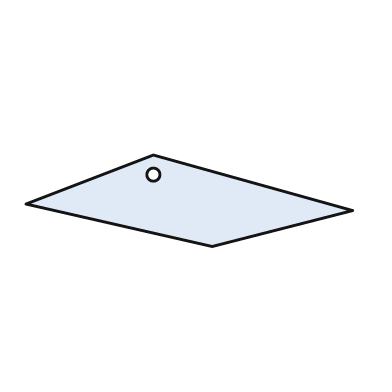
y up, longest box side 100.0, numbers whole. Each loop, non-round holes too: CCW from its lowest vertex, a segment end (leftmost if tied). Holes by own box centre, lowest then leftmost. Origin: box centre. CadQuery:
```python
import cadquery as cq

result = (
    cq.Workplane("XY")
    .moveTo(7.0, -14.0)
    .lineTo(50.0, -3.0)
    .lineTo(-11.0, 14.0)
    .lineTo(-50.0, -1.0)
    .close()
    .moveTo(-11.0, 8.0)
    .circle(2.0)
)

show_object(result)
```